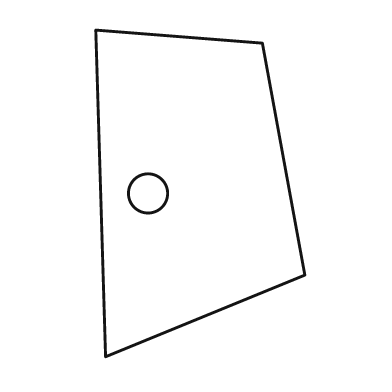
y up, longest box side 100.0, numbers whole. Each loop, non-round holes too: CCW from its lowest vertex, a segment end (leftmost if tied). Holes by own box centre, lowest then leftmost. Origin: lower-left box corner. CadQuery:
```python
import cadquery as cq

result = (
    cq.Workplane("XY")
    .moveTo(3.0, 0.0)
    .lineTo(64.0, 25.0)
    .lineTo(51.0, 96.0)
    .lineTo(0.0, 100.0)
    .close()
    .moveTo(16.0, 50.0)
    .circle(6.0)
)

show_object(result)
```